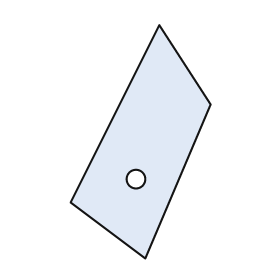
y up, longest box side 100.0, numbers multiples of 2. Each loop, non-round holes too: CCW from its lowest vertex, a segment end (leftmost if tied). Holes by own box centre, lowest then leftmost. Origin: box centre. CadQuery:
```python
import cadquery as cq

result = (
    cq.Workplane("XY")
    .moveTo(2.0, -50.0)
    .lineTo(30.0, 16.0)
    .lineTo(8.0, 50.0)
    .lineTo(-30.0, -26.0)
    .close()
    .moveTo(-2.0, -16.0)
    .circle(4.0)
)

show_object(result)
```